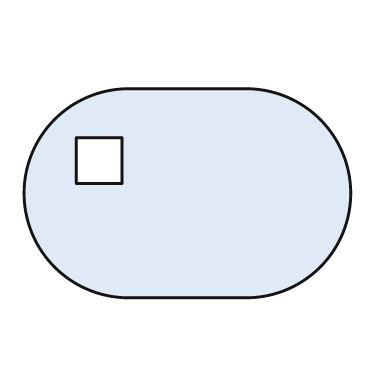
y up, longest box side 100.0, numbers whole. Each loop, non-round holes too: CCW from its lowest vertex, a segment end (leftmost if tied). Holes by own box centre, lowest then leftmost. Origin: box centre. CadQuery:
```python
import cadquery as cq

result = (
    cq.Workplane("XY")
    .moveTo(-18.0, -32.0)
    .lineTo(18.0, -32.0)
    .threePointArc((50.0, 0.0), (18.0, 32.0))
    .lineTo(-18.0, 32.0)
    .threePointArc((-50.0, 0.0), (-18.0, -32.0))
    .close()
    .moveTo(-34.0, 3.0)
    .lineTo(-20.0, 3.0)
    .lineTo(-20.0, 17.0)
    .lineTo(-34.0, 17.0)
    .close()
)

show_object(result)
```